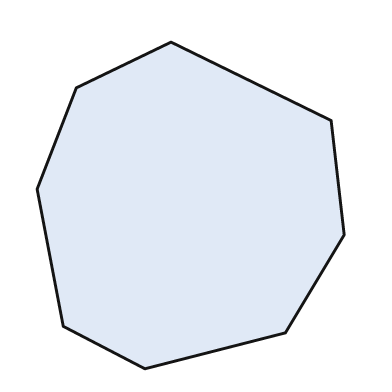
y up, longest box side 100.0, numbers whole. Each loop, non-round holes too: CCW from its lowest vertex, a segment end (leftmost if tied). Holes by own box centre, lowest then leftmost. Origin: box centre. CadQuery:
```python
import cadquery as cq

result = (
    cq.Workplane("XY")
    .moveTo(-14.0, -50.0)
    .lineTo(29.0, -39.0)
    .lineTo(47.0, -9.0)
    .lineTo(43.0, 26.0)
    .lineTo(-6.0, 50.0)
    .lineTo(-35.0, 36.0)
    .lineTo(-47.0, 5.0)
    .lineTo(-39.0, -37.0)
    .close()
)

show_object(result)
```